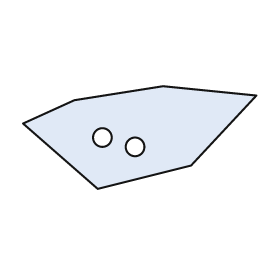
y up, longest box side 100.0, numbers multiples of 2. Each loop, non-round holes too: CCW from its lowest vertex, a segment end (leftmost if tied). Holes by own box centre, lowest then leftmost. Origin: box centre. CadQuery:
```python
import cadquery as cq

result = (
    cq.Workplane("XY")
    .moveTo(-18.0, -22.0)
    .lineTo(22.0, -12.0)
    .lineTo(50.0, 18.0)
    .lineTo(10.0, 22.0)
    .lineTo(-28.0, 16.0)
    .lineTo(-50.0, 6.0)
    .close()
    .moveTo(-2.0, -4.0)
    .circle(4.0)
    .moveTo(-16.0, 0.0)
    .circle(4.0)
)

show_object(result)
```